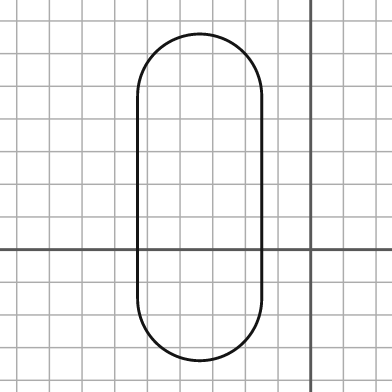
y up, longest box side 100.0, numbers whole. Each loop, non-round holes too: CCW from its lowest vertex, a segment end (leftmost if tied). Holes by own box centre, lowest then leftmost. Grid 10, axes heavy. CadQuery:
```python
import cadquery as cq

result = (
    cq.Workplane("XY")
    .moveTo(-53.0, -15.0)
    .threePointArc((-34.0, -34.0), (-15.0, -15.0))
    .lineTo(-15.0, 47.0)
    .threePointArc((-34.0, 66.0), (-53.0, 47.0))
    .close()
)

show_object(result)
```